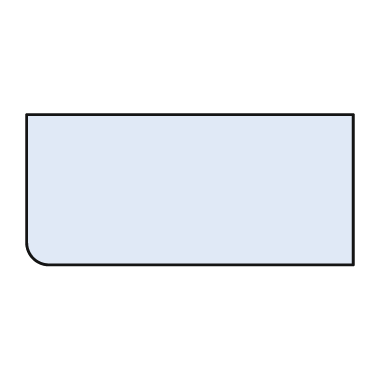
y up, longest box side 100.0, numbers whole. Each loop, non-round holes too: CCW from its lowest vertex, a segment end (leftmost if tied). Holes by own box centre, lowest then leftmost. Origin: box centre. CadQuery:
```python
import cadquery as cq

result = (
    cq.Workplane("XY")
    .moveTo(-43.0, -23.0)
    .lineTo(50.0, -23.0)
    .lineTo(50.0, 23.0)
    .lineTo(-50.0, 23.0)
    .lineTo(-50.0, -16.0)
    .threePointArc((-48.0, -21.0), (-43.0, -23.0))
    .close()
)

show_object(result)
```